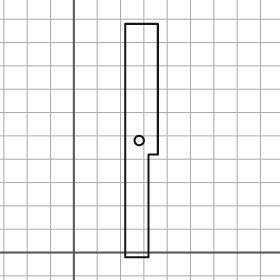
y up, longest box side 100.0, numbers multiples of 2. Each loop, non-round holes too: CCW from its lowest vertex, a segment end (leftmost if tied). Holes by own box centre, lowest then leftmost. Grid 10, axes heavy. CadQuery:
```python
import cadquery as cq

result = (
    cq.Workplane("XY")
    .moveTo(22.0, -2.0)
    .lineTo(32.0, -2.0)
    .lineTo(32.0, 42.0)
    .lineTo(36.0, 42.0)
    .lineTo(36.0, 98.0)
    .lineTo(22.0, 98.0)
    .close()
    .moveTo(28.0, 48.0)
    .circle(2.0)
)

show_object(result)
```